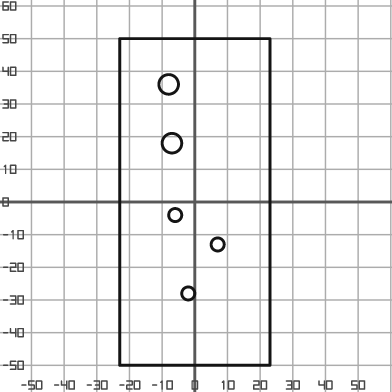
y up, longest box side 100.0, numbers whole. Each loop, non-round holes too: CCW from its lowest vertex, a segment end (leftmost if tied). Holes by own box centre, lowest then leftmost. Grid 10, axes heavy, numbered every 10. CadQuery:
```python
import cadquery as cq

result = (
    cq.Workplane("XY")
    .moveTo(-23.0, -50.0)
    .lineTo(23.0, -50.0)
    .lineTo(23.0, 50.0)
    .lineTo(-23.0, 50.0)
    .close()
    .moveTo(-2.0, -28.0)
    .circle(2.0)
    .moveTo(7.0, -13.0)
    .circle(2.0)
    .moveTo(-6.0, -4.0)
    .circle(2.0)
    .moveTo(-7.0, 18.0)
    .circle(3.0)
    .moveTo(-8.0, 36.0)
    .circle(3.0)
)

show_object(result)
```